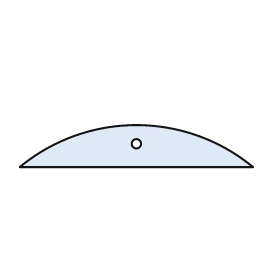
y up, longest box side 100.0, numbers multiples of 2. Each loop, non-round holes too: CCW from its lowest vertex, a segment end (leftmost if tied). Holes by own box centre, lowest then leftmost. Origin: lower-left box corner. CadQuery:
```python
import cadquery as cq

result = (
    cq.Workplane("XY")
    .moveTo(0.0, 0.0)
    .lineTo(100.0, 0.0)
    .threePointArc((50.0, 18.0), (0.0, 0.0))
    .close()
    .moveTo(50.0, 10.0)
    .circle(2.0)
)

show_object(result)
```